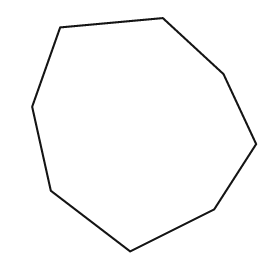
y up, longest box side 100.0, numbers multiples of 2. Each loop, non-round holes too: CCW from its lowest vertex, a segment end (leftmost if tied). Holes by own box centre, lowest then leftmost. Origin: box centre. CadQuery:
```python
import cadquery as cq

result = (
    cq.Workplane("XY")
    .moveTo(-6.0, -50.0)
    .lineTo(30.0, -32.0)
    .lineTo(48.0, -4.0)
    .lineTo(34.0, 26.0)
    .lineTo(8.0, 50.0)
    .lineTo(-36.0, 46.0)
    .lineTo(-48.0, 12.0)
    .lineTo(-40.0, -24.0)
    .close()
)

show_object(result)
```